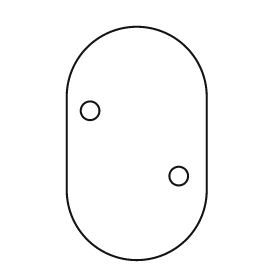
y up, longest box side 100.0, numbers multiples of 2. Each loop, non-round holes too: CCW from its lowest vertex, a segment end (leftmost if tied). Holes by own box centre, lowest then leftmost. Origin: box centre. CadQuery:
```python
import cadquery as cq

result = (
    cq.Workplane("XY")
    .moveTo(-30.0, -20.0)
    .threePointArc((0.0, -50.0), (30.0, -20.0))
    .lineTo(30.0, 20.0)
    .threePointArc((0.0, 50.0), (-30.0, 20.0))
    .close()
    .moveTo(18.0, -14.0)
    .circle(4.0)
    .moveTo(-20.0, 14.0)
    .circle(4.0)
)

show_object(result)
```